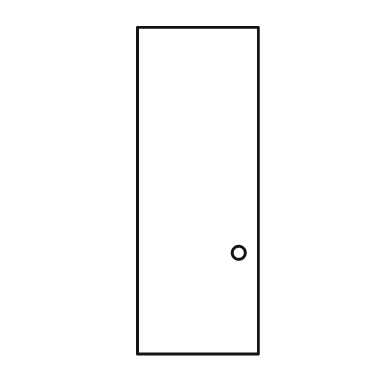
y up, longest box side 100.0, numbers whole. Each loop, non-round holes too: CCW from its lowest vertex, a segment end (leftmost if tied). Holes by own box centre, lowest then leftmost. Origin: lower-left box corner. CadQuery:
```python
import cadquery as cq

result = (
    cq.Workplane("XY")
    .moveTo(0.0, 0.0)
    .lineTo(37.0, 0.0)
    .lineTo(37.0, 100.0)
    .lineTo(0.0, 100.0)
    .close()
    .moveTo(31.0, 31.0)
    .circle(2.0)
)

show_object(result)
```